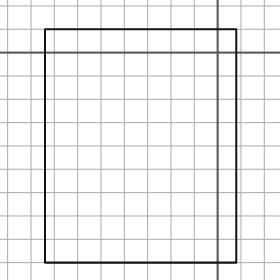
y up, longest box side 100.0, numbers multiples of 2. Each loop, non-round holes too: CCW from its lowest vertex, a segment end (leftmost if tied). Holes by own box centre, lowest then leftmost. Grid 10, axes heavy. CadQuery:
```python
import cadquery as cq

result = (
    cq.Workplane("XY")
    .moveTo(-74.0, -90.0)
    .lineTo(8.0, -90.0)
    .lineTo(8.0, 10.0)
    .lineTo(-74.0, 10.0)
    .close()
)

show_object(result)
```